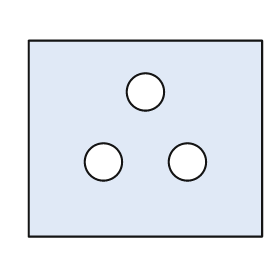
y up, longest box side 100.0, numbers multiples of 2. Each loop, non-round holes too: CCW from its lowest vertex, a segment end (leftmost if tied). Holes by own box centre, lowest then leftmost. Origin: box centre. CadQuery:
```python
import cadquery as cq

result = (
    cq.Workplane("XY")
    .moveTo(-50.0, -42.0)
    .lineTo(50.0, -42.0)
    .lineTo(50.0, 42.0)
    .lineTo(-50.0, 42.0)
    .close()
    .moveTo(-18.0, -10.0)
    .circle(8.0)
    .moveTo(18.0, -10.0)
    .circle(8.0)
    .moveTo(0.0, 20.0)
    .circle(8.0)
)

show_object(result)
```